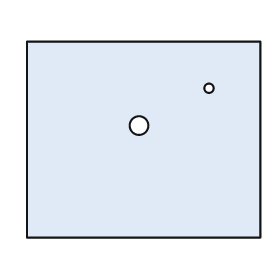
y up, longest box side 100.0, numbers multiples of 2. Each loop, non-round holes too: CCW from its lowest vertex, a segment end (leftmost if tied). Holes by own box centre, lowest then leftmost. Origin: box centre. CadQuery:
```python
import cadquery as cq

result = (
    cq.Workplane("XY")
    .moveTo(-50.0, -42.0)
    .lineTo(50.0, -42.0)
    .lineTo(50.0, 42.0)
    .lineTo(-50.0, 42.0)
    .close()
    .moveTo(-2.0, 6.0)
    .circle(4.0)
    .moveTo(28.0, 22.0)
    .circle(2.0)
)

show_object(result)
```